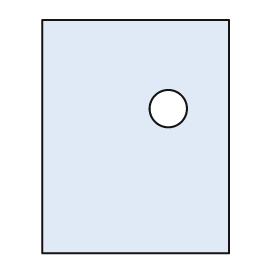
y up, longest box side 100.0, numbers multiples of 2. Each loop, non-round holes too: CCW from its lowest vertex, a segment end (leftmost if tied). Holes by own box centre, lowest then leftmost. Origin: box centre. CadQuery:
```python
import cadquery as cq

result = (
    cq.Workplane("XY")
    .moveTo(-40.0, -50.0)
    .lineTo(40.0, -50.0)
    .lineTo(40.0, 50.0)
    .lineTo(-40.0, 50.0)
    .close()
    .moveTo(14.0, 12.0)
    .circle(8.0)
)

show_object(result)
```